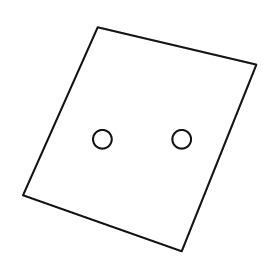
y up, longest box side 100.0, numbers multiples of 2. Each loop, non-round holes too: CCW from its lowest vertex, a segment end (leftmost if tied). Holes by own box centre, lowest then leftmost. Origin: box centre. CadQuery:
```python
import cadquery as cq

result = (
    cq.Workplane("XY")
    .moveTo(18.0, -48.0)
    .lineTo(50.0, 32.0)
    .lineTo(-18.0, 48.0)
    .lineTo(-50.0, -24.0)
    .close()
    .moveTo(-16.0, 0.0)
    .circle(4.0)
    .moveTo(18.0, 0.0)
    .circle(4.0)
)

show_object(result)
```